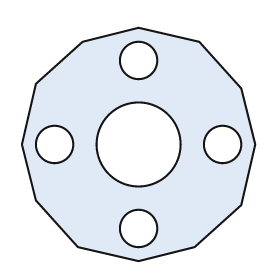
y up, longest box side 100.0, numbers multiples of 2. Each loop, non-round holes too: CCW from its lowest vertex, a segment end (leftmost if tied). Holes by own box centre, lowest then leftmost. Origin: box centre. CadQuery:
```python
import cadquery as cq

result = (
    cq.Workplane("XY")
    .moveTo(0.0, -50.0)
    .lineTo(24.0, -44.0)
    .lineTo(44.0, -26.0)
    .lineTo(50.0, 0.0)
    .lineTo(44.0, 24.0)
    .lineTo(26.0, 44.0)
    .lineTo(0.0, 50.0)
    .lineTo(-24.0, 44.0)
    .lineTo(-44.0, 26.0)
    .lineTo(-50.0, 0.0)
    .lineTo(-44.0, -24.0)
    .lineTo(-26.0, -44.0)
    .close()
    .moveTo(0.0, -36.0)
    .circle(8.0)
    .moveTo(-36.0, 0.0)
    .circle(8.0)
    .moveTo(0.0, 0.0)
    .circle(18.0)
    .moveTo(36.0, 0.0)
    .circle(8.0)
    .moveTo(0.0, 36.0)
    .circle(8.0)
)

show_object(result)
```